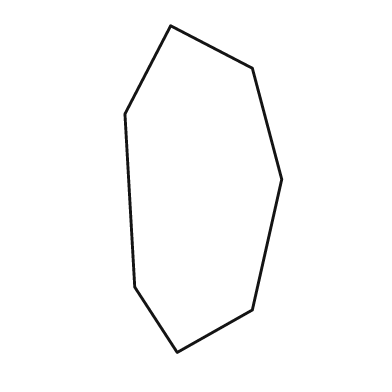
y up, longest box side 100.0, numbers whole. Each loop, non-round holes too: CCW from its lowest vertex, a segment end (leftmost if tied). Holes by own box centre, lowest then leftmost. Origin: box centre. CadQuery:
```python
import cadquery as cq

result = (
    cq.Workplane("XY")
    .moveTo(-8.0, -50.0)
    .lineTo(15.0, -37.0)
    .lineTo(24.0, 3.0)
    .lineTo(15.0, 37.0)
    .lineTo(-10.0, 50.0)
    .lineTo(-24.0, 23.0)
    .lineTo(-21.0, -30.0)
    .close()
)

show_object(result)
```